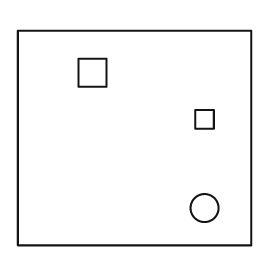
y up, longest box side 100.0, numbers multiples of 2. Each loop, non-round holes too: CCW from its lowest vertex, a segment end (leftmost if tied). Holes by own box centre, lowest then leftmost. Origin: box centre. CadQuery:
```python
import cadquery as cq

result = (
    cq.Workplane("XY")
    .moveTo(-50.0, -46.0)
    .lineTo(50.0, -46.0)
    .lineTo(50.0, 46.0)
    .lineTo(-50.0, 46.0)
    .close()
    .moveTo(30.0, -30.0)
    .circle(6.0)
    .moveTo(26.0, 4.0)
    .lineTo(34.0, 4.0)
    .lineTo(34.0, 12.0)
    .lineTo(26.0, 12.0)
    .close()
    .moveTo(-24.0, 22.0)
    .lineTo(-12.0, 22.0)
    .lineTo(-12.0, 34.0)
    .lineTo(-24.0, 34.0)
    .close()
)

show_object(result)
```